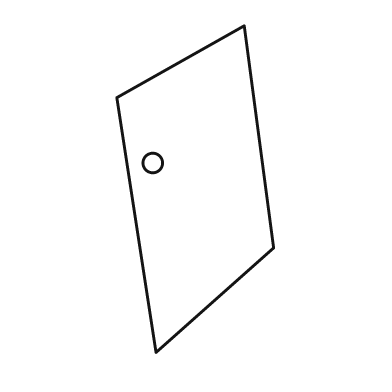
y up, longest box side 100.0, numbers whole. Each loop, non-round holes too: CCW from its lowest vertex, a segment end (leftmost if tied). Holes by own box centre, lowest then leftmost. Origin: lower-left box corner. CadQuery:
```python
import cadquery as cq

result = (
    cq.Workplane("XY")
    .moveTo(12.0, 0.0)
    .lineTo(48.0, 32.0)
    .lineTo(39.0, 100.0)
    .lineTo(0.0, 78.0)
    .close()
    .moveTo(11.0, 58.0)
    .circle(3.0)
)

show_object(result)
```